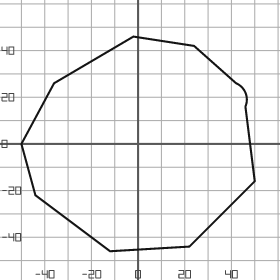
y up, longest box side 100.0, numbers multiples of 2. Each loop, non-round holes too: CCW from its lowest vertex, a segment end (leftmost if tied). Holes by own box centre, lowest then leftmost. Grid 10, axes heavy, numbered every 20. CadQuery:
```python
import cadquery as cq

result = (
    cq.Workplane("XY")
    .moveTo(-12.0, -46.0)
    .lineTo(22.0, -44.0)
    .lineTo(50.0, -16.0)
    .lineTo(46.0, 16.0)
    .threePointArc((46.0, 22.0), (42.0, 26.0))
    .lineTo(24.0, 42.0)
    .lineTo(-2.0, 46.0)
    .lineTo(-36.0, 26.0)
    .lineTo(-50.0, 0.0)
    .lineTo(-44.0, -22.0)
    .close()
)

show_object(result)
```